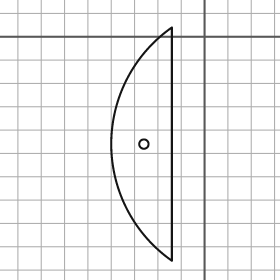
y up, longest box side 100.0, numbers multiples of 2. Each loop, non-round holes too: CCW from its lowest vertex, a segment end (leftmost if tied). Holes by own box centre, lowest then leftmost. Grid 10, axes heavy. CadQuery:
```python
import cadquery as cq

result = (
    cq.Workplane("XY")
    .moveTo(-14.0, -96.0)
    .lineTo(-14.0, 4.0)
    .threePointArc((-40.0, -46.0), (-14.0, -96.0))
    .close()
    .moveTo(-26.0, -46.0)
    .circle(2.0)
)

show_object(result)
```